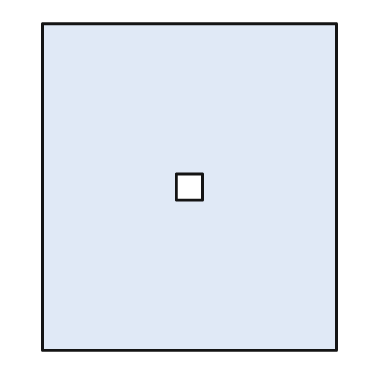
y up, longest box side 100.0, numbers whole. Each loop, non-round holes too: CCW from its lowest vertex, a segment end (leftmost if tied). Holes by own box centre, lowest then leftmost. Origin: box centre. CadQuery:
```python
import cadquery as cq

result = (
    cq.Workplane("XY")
    .moveTo(-45.0, -50.0)
    .lineTo(45.0, -50.0)
    .lineTo(45.0, 50.0)
    .lineTo(-45.0, 50.0)
    .close()
    .moveTo(-4.0, -4.0)
    .lineTo(4.0, -4.0)
    .lineTo(4.0, 4.0)
    .lineTo(-4.0, 4.0)
    .close()
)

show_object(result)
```